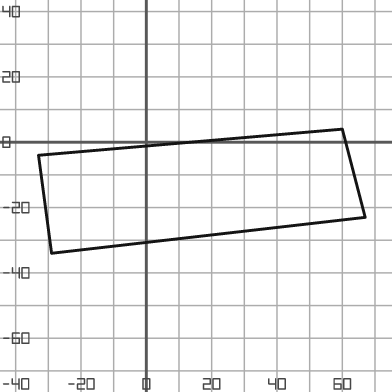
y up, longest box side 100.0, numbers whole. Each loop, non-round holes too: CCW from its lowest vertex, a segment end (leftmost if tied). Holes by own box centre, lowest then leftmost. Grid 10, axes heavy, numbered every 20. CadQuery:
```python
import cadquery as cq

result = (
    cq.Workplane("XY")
    .moveTo(-29.0, -34.0)
    .lineTo(67.0, -23.0)
    .lineTo(60.0, 4.0)
    .lineTo(-33.0, -4.0)
    .close()
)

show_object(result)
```